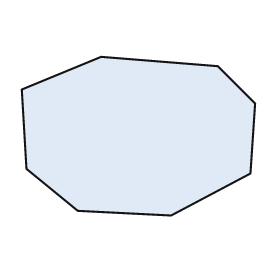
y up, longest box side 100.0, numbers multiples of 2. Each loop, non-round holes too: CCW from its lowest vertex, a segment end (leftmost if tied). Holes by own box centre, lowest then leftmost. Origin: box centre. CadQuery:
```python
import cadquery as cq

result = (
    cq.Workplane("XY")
    .moveTo(14.0, -34.0)
    .lineTo(48.0, -16.0)
    .lineTo(50.0, 14.0)
    .lineTo(34.0, 30.0)
    .lineTo(-16.0, 34.0)
    .lineTo(-50.0, 20.0)
    .lineTo(-48.0, -14.0)
    .lineTo(-26.0, -32.0)
    .close()
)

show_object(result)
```